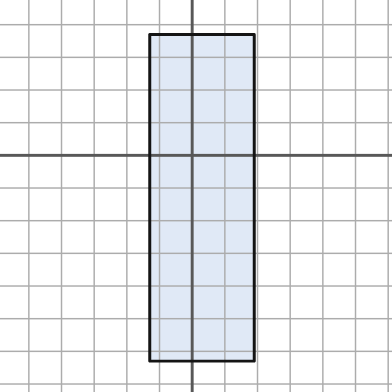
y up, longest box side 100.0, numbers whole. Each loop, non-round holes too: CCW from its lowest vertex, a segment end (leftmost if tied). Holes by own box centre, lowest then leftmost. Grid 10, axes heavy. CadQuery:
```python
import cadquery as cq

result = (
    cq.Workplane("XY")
    .moveTo(-13.0, -63.0)
    .lineTo(19.0, -63.0)
    .lineTo(19.0, 37.0)
    .lineTo(-13.0, 37.0)
    .close()
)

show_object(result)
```